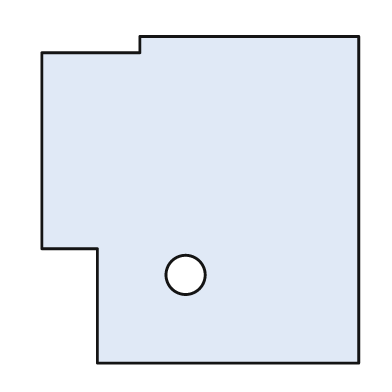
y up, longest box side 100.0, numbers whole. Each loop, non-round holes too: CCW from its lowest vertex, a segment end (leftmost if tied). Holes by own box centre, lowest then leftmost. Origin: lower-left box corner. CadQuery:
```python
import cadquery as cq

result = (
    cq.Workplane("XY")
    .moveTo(17.0, 0.0)
    .lineTo(97.0, 0.0)
    .lineTo(97.0, 100.0)
    .lineTo(30.0, 100.0)
    .lineTo(30.0, 95.0)
    .lineTo(0.0, 95.0)
    .lineTo(0.0, 35.0)
    .lineTo(17.0, 35.0)
    .close()
    .moveTo(44.0, 27.0)
    .circle(6.0)
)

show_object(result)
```